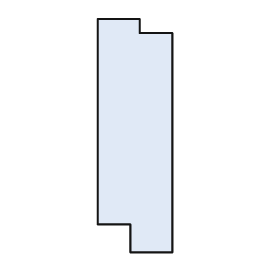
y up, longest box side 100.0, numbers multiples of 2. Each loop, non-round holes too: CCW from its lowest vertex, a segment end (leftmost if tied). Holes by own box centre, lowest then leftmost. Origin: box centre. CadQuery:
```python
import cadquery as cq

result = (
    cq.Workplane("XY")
    .moveTo(-2.0, -50.0)
    .lineTo(16.0, -50.0)
    .lineTo(16.0, 44.0)
    .lineTo(2.0, 44.0)
    .lineTo(2.0, 50.0)
    .lineTo(-16.0, 50.0)
    .lineTo(-16.0, -38.0)
    .lineTo(-2.0, -38.0)
    .close()
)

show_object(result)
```